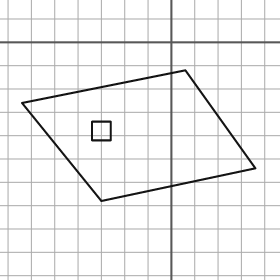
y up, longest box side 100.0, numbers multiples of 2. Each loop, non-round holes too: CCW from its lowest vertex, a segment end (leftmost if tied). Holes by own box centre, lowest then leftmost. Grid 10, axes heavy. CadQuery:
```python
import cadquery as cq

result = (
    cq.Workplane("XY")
    .moveTo(-30.0, -68.0)
    .lineTo(36.0, -54.0)
    .lineTo(6.0, -12.0)
    .lineTo(-64.0, -26.0)
    .close()
    .moveTo(-34.0, -42.0)
    .lineTo(-26.0, -42.0)
    .lineTo(-26.0, -34.0)
    .lineTo(-34.0, -34.0)
    .close()
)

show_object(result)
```